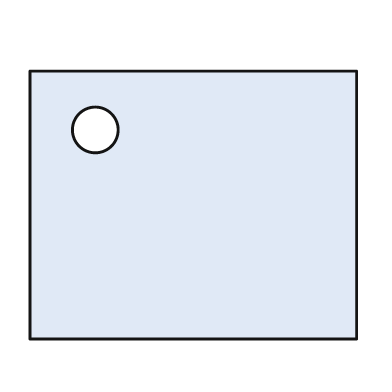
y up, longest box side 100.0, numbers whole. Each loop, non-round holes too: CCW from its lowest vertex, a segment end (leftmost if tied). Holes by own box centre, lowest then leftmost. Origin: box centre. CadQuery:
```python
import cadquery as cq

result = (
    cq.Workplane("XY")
    .moveTo(-50.0, -41.0)
    .lineTo(50.0, -41.0)
    .lineTo(50.0, 41.0)
    .lineTo(-50.0, 41.0)
    .close()
    .moveTo(-30.0, 23.0)
    .circle(7.0)
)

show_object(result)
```